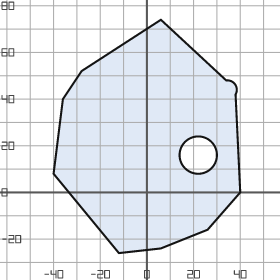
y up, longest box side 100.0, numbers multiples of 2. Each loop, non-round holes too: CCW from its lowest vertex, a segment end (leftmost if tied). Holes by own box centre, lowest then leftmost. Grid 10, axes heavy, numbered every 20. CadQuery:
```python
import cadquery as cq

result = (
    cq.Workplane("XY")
    .moveTo(-12.0, -26.0)
    .lineTo(6.0, -24.0)
    .lineTo(26.0, -16.0)
    .lineTo(40.0, 0.0)
    .lineTo(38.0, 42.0)
    .threePointArc((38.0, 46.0), (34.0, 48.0))
    .lineTo(6.0, 74.0)
    .lineTo(-28.0, 52.0)
    .lineTo(-36.0, 40.0)
    .lineTo(-40.0, 8.0)
    .close()
    .moveTo(22.0, 16.0)
    .circle(8.0)
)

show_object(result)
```